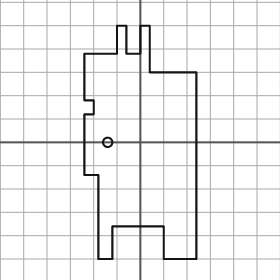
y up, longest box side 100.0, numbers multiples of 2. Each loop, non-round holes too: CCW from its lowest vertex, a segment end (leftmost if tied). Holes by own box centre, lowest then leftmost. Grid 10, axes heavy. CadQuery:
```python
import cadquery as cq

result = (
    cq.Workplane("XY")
    .moveTo(-18.0, -50.0)
    .lineTo(-12.0, -50.0)
    .lineTo(-12.0, -36.0)
    .lineTo(10.0, -36.0)
    .lineTo(10.0, -50.0)
    .lineTo(24.0, -50.0)
    .lineTo(24.0, 30.0)
    .lineTo(4.0, 30.0)
    .lineTo(4.0, 50.0)
    .lineTo(0.0, 50.0)
    .lineTo(0.0, 38.0)
    .lineTo(-6.0, 38.0)
    .lineTo(-6.0, 50.0)
    .lineTo(-10.0, 50.0)
    .lineTo(-10.0, 38.0)
    .lineTo(-24.0, 38.0)
    .lineTo(-24.0, 18.0)
    .lineTo(-20.0, 18.0)
    .lineTo(-20.0, 12.0)
    .lineTo(-24.0, 12.0)
    .lineTo(-24.0, -14.0)
    .lineTo(-18.0, -14.0)
    .close()
    .moveTo(-14.0, 0.0)
    .circle(2.0)
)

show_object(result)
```